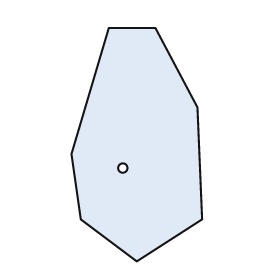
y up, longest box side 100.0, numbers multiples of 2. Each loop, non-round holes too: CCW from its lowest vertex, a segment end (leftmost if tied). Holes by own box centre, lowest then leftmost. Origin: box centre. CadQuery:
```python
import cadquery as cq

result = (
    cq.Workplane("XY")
    .moveTo(0.0, -50.0)
    .lineTo(28.0, -32.0)
    .lineTo(26.0, 16.0)
    .lineTo(8.0, 50.0)
    .lineTo(-12.0, 50.0)
    .lineTo(-28.0, -4.0)
    .lineTo(-24.0, -32.0)
    .close()
    .moveTo(-6.0, -10.0)
    .circle(2.0)
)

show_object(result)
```